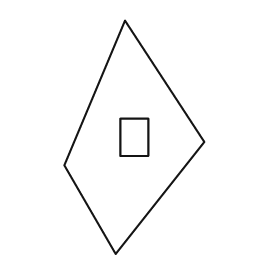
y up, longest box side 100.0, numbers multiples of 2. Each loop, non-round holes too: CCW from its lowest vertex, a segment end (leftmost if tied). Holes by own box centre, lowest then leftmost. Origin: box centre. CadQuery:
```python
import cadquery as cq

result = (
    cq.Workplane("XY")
    .moveTo(-8.0, -50.0)
    .lineTo(30.0, -2.0)
    .lineTo(-4.0, 50.0)
    .lineTo(-30.0, -12.0)
    .close()
    .moveTo(-6.0, -8.0)
    .lineTo(6.0, -8.0)
    .lineTo(6.0, 8.0)
    .lineTo(-6.0, 8.0)
    .close()
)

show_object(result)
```